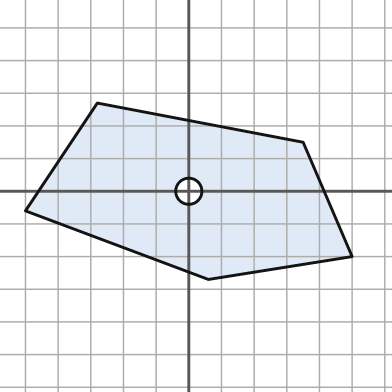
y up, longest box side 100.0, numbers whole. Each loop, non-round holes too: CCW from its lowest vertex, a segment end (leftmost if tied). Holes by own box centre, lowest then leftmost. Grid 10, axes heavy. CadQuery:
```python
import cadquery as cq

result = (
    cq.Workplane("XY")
    .moveTo(6.0, -27.0)
    .lineTo(50.0, -20.0)
    .lineTo(35.0, 15.0)
    .lineTo(-28.0, 27.0)
    .lineTo(-50.0, -6.0)
    .close()
    .moveTo(0.0, 0.0)
    .circle(4.0)
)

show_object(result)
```